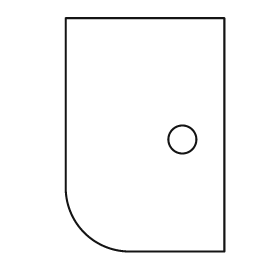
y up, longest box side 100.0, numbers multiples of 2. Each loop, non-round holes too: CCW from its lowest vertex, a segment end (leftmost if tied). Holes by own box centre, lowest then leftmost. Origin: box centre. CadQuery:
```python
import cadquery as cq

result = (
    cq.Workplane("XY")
    .moveTo(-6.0, -50.0)
    .lineTo(34.0, -50.0)
    .lineTo(34.0, 50.0)
    .lineTo(-34.0, 50.0)
    .lineTo(-34.0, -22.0)
    .threePointArc((-26.0, -42.0), (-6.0, -50.0))
    .close()
    .moveTo(16.0, -2.0)
    .circle(6.0)
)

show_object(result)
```